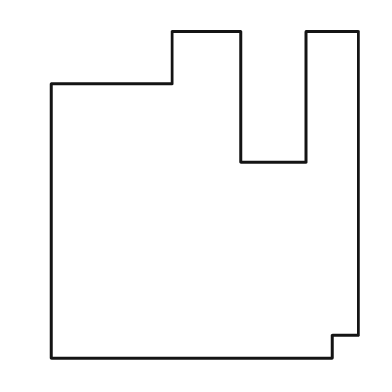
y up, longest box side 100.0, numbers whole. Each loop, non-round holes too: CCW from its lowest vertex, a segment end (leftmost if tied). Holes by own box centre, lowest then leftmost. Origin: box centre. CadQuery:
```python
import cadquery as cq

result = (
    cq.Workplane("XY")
    .moveTo(-47.0, -50.0)
    .lineTo(39.0, -50.0)
    .lineTo(39.0, -43.0)
    .lineTo(47.0, -43.0)
    .lineTo(47.0, 50.0)
    .lineTo(31.0, 50.0)
    .lineTo(31.0, 10.0)
    .lineTo(11.0, 10.0)
    .lineTo(11.0, 50.0)
    .lineTo(-10.0, 50.0)
    .lineTo(-10.0, 34.0)
    .lineTo(-47.0, 34.0)
    .close()
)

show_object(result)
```